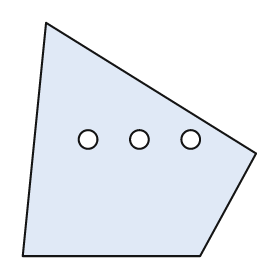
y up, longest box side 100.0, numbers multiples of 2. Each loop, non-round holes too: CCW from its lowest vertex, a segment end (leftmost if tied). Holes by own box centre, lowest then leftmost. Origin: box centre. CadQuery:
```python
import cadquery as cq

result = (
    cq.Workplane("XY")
    .moveTo(-50.0, -50.0)
    .lineTo(26.0, -50.0)
    .lineTo(50.0, -6.0)
    .lineTo(-40.0, 50.0)
    .close()
    .moveTo(-22.0, 0.0)
    .circle(4.0)
    .moveTo(0.0, 0.0)
    .circle(4.0)
    .moveTo(22.0, 0.0)
    .circle(4.0)
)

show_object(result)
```